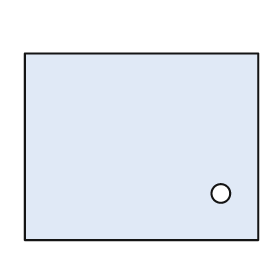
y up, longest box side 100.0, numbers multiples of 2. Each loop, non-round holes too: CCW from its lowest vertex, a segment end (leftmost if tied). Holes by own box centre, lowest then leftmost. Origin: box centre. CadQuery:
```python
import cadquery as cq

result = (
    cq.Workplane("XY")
    .moveTo(-50.0, -40.0)
    .lineTo(50.0, -40.0)
    .lineTo(50.0, 40.0)
    .lineTo(-50.0, 40.0)
    .close()
    .moveTo(34.0, -20.0)
    .circle(4.0)
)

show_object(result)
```